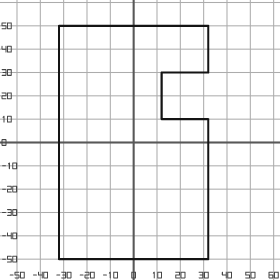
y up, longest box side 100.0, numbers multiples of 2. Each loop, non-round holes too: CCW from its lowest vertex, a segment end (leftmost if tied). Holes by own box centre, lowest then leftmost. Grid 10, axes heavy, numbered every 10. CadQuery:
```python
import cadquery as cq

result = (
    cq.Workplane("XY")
    .moveTo(-32.0, -50.0)
    .lineTo(32.0, -50.0)
    .lineTo(32.0, 10.0)
    .lineTo(12.0, 10.0)
    .lineTo(12.0, 30.0)
    .lineTo(32.0, 30.0)
    .lineTo(32.0, 50.0)
    .lineTo(-32.0, 50.0)
    .close()
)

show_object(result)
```